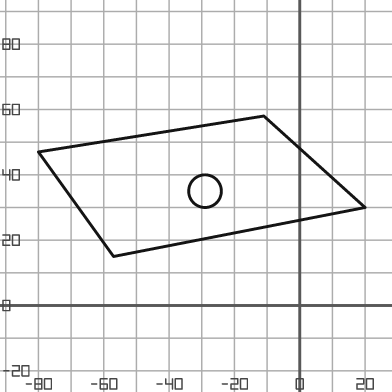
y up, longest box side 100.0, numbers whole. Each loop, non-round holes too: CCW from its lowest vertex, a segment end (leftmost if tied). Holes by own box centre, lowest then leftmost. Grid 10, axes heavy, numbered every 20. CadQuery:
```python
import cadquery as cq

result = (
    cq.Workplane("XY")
    .moveTo(-57.0, 15.0)
    .lineTo(20.0, 30.0)
    .lineTo(-11.0, 58.0)
    .lineTo(-80.0, 47.0)
    .close()
    .moveTo(-29.0, 35.0)
    .circle(5.0)
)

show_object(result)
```